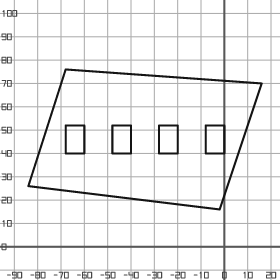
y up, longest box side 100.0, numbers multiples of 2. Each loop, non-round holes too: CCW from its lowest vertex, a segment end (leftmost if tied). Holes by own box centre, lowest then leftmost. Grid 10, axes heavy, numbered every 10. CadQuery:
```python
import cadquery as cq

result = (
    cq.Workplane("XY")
    .moveTo(-2.0, 16.0)
    .lineTo(16.0, 70.0)
    .lineTo(-68.0, 76.0)
    .lineTo(-84.0, 26.0)
    .close()
    .moveTo(-68.0, 40.0)
    .lineTo(-60.0, 40.0)
    .lineTo(-60.0, 52.0)
    .lineTo(-68.0, 52.0)
    .close()
    .moveTo(-48.0, 40.0)
    .lineTo(-40.0, 40.0)
    .lineTo(-40.0, 52.0)
    .lineTo(-48.0, 52.0)
    .close()
    .moveTo(-28.0, 40.0)
    .lineTo(-20.0, 40.0)
    .lineTo(-20.0, 52.0)
    .lineTo(-28.0, 52.0)
    .close()
    .moveTo(-8.0, 40.0)
    .lineTo(0.0, 40.0)
    .lineTo(0.0, 52.0)
    .lineTo(-8.0, 52.0)
    .close()
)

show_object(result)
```